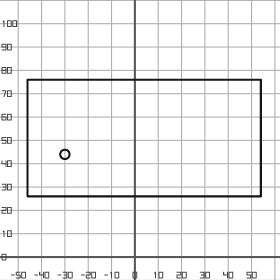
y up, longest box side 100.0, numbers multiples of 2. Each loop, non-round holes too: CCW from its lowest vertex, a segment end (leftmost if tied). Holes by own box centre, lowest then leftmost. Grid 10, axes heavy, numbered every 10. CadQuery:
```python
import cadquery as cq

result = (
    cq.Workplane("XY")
    .moveTo(-46.0, 26.0)
    .lineTo(54.0, 26.0)
    .lineTo(54.0, 76.0)
    .lineTo(-46.0, 76.0)
    .close()
    .moveTo(-30.0, 44.0)
    .circle(2.0)
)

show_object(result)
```